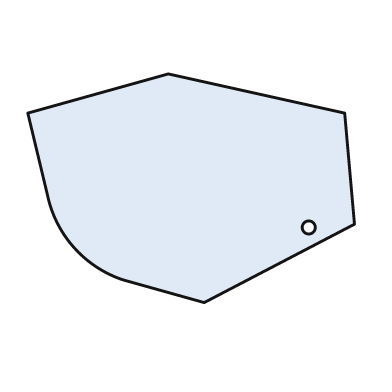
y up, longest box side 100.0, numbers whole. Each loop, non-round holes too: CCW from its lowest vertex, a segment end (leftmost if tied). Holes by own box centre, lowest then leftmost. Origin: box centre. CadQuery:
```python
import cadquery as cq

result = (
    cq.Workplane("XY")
    .moveTo(4.0, -35.0)
    .lineTo(50.0, -11.0)
    .lineTo(47.0, 23.0)
    .lineTo(-7.0, 35.0)
    .lineTo(-50.0, 23.0)
    .lineTo(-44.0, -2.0)
    .threePointArc((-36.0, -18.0), (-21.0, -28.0))
    .close()
    .moveTo(36.0, -12.0)
    .circle(2.0)
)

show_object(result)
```